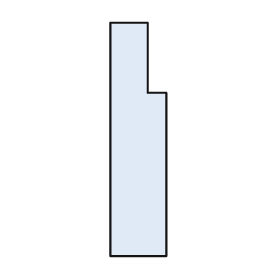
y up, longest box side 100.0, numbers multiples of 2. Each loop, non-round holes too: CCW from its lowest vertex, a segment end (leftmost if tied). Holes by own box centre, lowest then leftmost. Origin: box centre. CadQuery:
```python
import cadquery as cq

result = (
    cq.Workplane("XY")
    .moveTo(-12.0, -50.0)
    .lineTo(12.0, -50.0)
    .lineTo(12.0, 20.0)
    .lineTo(4.0, 20.0)
    .lineTo(4.0, 50.0)
    .lineTo(-12.0, 50.0)
    .close()
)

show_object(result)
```